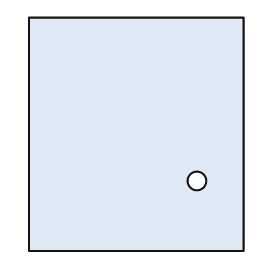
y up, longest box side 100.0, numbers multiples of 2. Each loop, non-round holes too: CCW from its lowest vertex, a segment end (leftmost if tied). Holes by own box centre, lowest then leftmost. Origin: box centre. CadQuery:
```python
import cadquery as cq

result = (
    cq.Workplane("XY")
    .moveTo(-46.0, -50.0)
    .lineTo(46.0, -50.0)
    .lineTo(46.0, 50.0)
    .lineTo(-46.0, 50.0)
    .close()
    .moveTo(26.0, -20.0)
    .circle(4.0)
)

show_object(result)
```